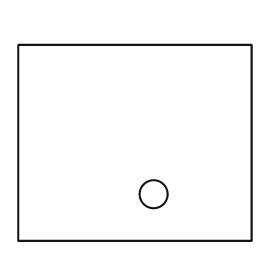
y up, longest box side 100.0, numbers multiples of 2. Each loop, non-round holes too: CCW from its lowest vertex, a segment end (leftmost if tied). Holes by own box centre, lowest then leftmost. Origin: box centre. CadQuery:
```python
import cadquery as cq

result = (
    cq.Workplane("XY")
    .moveTo(-50.0, -42.0)
    .lineTo(50.0, -42.0)
    .lineTo(50.0, 42.0)
    .lineTo(-50.0, 42.0)
    .close()
    .moveTo(8.0, -22.0)
    .circle(6.0)
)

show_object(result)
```